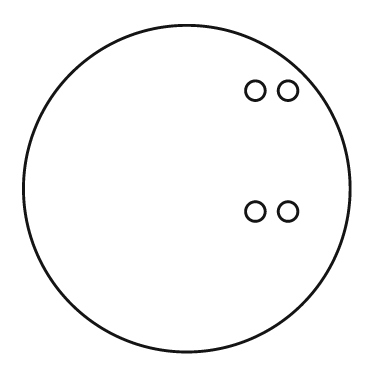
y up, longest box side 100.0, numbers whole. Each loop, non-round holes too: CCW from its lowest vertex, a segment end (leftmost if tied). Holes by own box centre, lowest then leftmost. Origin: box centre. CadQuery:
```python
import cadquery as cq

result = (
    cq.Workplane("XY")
    .moveTo(0.0, 0.0)
    .circle(50.0)
    .moveTo(21.0, -7.0)
    .circle(3.0)
    .moveTo(31.0, -7.0)
    .circle(3.0)
    .moveTo(21.0, 30.0)
    .circle(3.0)
    .moveTo(31.0, 30.0)
    .circle(3.0)
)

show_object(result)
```